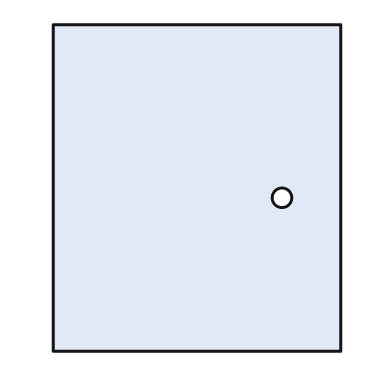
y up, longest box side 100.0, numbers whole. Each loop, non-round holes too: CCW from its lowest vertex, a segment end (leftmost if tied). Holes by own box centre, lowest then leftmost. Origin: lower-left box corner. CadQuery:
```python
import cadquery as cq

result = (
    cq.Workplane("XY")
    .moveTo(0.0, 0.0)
    .lineTo(88.0, 0.0)
    .lineTo(88.0, 100.0)
    .lineTo(0.0, 100.0)
    .close()
    .moveTo(70.0, 47.0)
    .circle(3.0)
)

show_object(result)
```